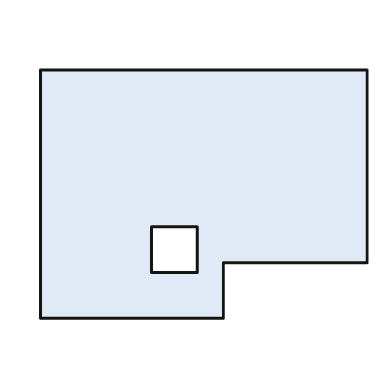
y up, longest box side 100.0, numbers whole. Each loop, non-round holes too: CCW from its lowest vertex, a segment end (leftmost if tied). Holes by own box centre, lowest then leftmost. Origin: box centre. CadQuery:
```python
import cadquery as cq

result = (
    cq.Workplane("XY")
    .moveTo(-50.0, -38.0)
    .lineTo(6.0, -38.0)
    .lineTo(6.0, -21.0)
    .lineTo(50.0, -21.0)
    .lineTo(50.0, 38.0)
    .lineTo(-50.0, 38.0)
    .close()
    .moveTo(-16.0, -24.0)
    .lineTo(-2.0, -24.0)
    .lineTo(-2.0, -10.0)
    .lineTo(-16.0, -10.0)
    .close()
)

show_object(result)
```